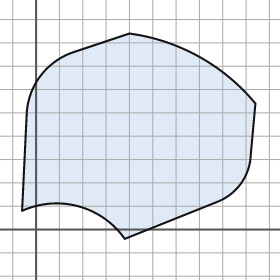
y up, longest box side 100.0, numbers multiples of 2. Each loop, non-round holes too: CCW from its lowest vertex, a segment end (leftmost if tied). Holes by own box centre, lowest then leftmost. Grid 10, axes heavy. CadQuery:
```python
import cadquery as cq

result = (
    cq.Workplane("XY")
    .moveTo(38.0, -4.0)
    .lineTo(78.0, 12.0)
    .threePointArc((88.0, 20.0), (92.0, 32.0))
    .lineTo(94.0, 54.0)
    .threePointArc((70.0, 74.0), (40.0, 84.0))
    .lineTo(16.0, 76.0)
    .threePointArc((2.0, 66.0), (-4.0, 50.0))
    .lineTo(-6.0, 8.0)
    .threePointArc((18.0, 10.0), (38.0, -4.0))
    .close()
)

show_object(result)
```